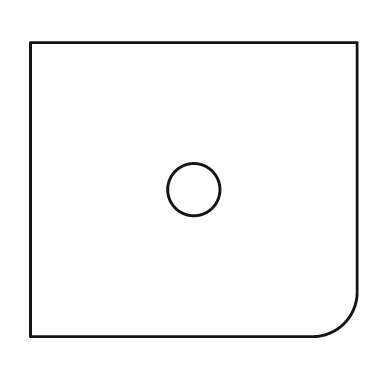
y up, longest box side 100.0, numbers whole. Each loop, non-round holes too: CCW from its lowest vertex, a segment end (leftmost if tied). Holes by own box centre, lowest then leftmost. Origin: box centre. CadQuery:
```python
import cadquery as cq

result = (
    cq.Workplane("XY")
    .moveTo(-50.0, -45.0)
    .lineTo(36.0, -45.0)
    .threePointArc((46.0, -41.0), (50.0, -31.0))
    .lineTo(50.0, 45.0)
    .lineTo(-50.0, 45.0)
    .close()
    .moveTo(0.0, 0.0)
    .circle(8.0)
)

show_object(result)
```